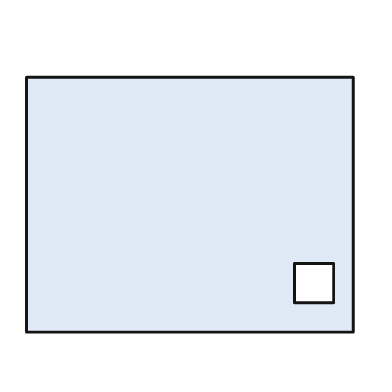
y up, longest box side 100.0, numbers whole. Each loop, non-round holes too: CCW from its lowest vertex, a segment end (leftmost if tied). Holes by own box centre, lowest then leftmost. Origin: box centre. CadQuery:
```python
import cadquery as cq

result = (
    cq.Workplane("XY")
    .moveTo(-50.0, -39.0)
    .lineTo(50.0, -39.0)
    .lineTo(50.0, 39.0)
    .lineTo(-50.0, 39.0)
    .close()
    .moveTo(32.0, -30.0)
    .lineTo(44.0, -30.0)
    .lineTo(44.0, -18.0)
    .lineTo(32.0, -18.0)
    .close()
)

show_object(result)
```